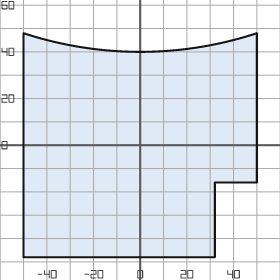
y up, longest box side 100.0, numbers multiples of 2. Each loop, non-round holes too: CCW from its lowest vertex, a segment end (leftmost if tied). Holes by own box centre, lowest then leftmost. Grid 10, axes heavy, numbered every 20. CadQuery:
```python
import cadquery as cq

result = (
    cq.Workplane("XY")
    .moveTo(-50.0, -48.0)
    .lineTo(32.0, -48.0)
    .lineTo(32.0, -16.0)
    .lineTo(50.0, -16.0)
    .lineTo(50.0, 48.0)
    .threePointArc((0.0, 40.0), (-50.0, 48.0))
    .close()
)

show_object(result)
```